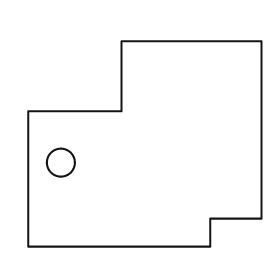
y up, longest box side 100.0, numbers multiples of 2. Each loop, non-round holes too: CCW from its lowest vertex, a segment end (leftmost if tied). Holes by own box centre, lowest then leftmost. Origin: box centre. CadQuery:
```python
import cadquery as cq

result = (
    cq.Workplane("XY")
    .moveTo(-50.0, -44.0)
    .lineTo(28.0, -44.0)
    .lineTo(28.0, -32.0)
    .lineTo(50.0, -32.0)
    .lineTo(50.0, 44.0)
    .lineTo(-10.0, 44.0)
    .lineTo(-10.0, 14.0)
    .lineTo(-50.0, 14.0)
    .close()
    .moveTo(-36.0, -8.0)
    .circle(6.0)
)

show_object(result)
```